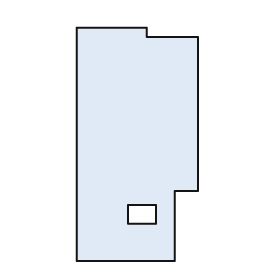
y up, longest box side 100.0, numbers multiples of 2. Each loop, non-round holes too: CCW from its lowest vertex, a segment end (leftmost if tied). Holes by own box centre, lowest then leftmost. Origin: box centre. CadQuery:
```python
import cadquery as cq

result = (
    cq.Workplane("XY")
    .moveTo(-26.0, -50.0)
    .lineTo(16.0, -50.0)
    .lineTo(16.0, -20.0)
    .lineTo(26.0, -20.0)
    .lineTo(26.0, 46.0)
    .lineTo(4.0, 46.0)
    .lineTo(4.0, 50.0)
    .lineTo(-26.0, 50.0)
    .close()
    .moveTo(-4.0, -34.0)
    .lineTo(8.0, -34.0)
    .lineTo(8.0, -26.0)
    .lineTo(-4.0, -26.0)
    .close()
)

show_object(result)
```